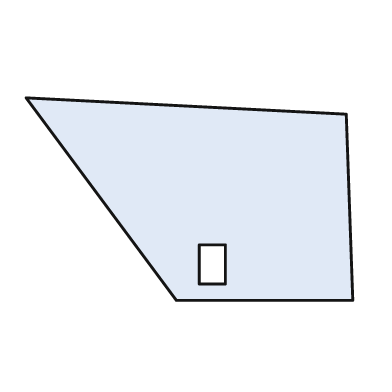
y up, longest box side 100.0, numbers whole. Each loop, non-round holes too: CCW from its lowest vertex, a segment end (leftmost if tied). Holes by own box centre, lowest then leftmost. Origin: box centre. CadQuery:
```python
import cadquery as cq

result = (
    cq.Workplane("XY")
    .moveTo(-4.0, -31.0)
    .lineTo(50.0, -31.0)
    .lineTo(48.0, 26.0)
    .lineTo(-50.0, 31.0)
    .close()
    .moveTo(3.0, -26.0)
    .lineTo(11.0, -26.0)
    .lineTo(11.0, -14.0)
    .lineTo(3.0, -14.0)
    .close()
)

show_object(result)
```